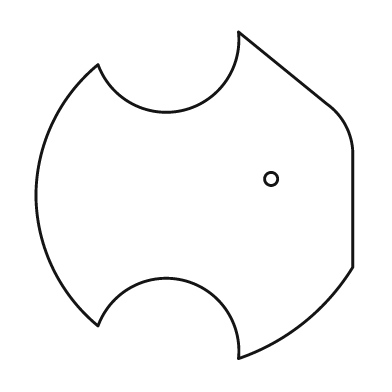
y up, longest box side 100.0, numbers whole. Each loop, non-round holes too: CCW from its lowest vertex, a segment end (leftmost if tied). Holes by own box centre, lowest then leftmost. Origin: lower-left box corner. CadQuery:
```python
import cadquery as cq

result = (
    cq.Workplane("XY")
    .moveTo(62.0, 0.0)
    .threePointArc((82.0, 11.0), (97.0, 28.0))
    .lineTo(97.0, 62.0)
    .threePointArc((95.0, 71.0), (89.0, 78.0))
    .lineTo(62.0, 100.0)
    .threePointArc((45.0, 76.0), (19.0, 90.0))
    .threePointArc((5.0, 72.0), (0.0, 50.0))
    .threePointArc((5.0, 28.0), (19.0, 10.0))
    .threePointArc((45.0, 24.0), (62.0, 0.0))
    .close()
    .moveTo(72.0, 55.0)
    .circle(2.0)
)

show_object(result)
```